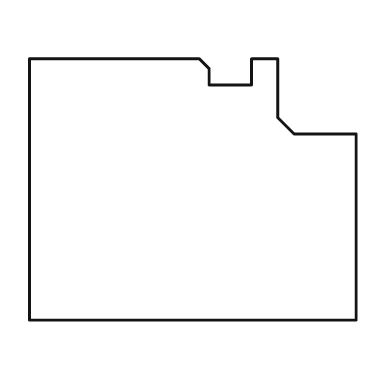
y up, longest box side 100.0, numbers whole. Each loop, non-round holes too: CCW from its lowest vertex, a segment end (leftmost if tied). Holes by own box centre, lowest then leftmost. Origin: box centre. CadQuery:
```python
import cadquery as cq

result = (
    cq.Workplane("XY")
    .moveTo(-50.0, -40.0)
    .lineTo(50.0, -40.0)
    .lineTo(50.0, 17.0)
    .lineTo(31.0, 17.0)
    .lineTo(26.0, 22.0)
    .lineTo(26.0, 40.0)
    .lineTo(18.0, 40.0)
    .lineTo(18.0, 32.0)
    .lineTo(5.0, 32.0)
    .lineTo(5.0, 37.0)
    .lineTo(2.0, 40.0)
    .lineTo(-50.0, 40.0)
    .close()
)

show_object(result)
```